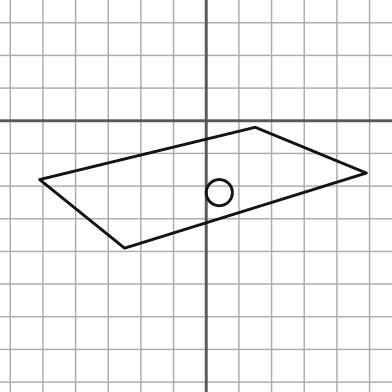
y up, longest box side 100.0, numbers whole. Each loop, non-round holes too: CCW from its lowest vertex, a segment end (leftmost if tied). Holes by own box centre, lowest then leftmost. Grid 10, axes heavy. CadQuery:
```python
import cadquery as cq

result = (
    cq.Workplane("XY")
    .moveTo(-25.0, -39.0)
    .lineTo(49.0, -16.0)
    .lineTo(15.0, -2.0)
    .lineTo(-51.0, -18.0)
    .close()
    .moveTo(4.0, -22.0)
    .circle(4.0)
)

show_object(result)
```